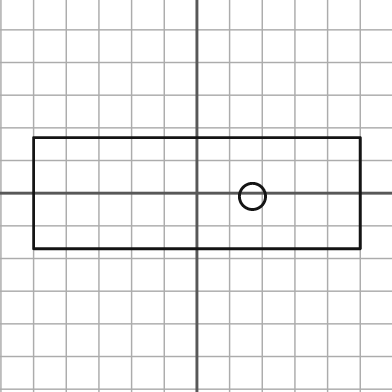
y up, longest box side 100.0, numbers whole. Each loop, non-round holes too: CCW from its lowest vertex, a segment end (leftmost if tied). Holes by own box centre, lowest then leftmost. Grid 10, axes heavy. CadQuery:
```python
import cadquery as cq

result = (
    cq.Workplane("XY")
    .moveTo(-50.0, -17.0)
    .lineTo(50.0, -17.0)
    .lineTo(50.0, 17.0)
    .lineTo(-50.0, 17.0)
    .close()
    .moveTo(17.0, -1.0)
    .circle(4.0)
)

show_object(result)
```